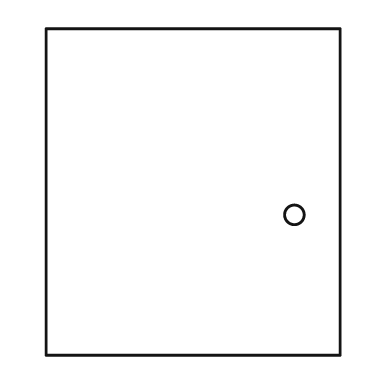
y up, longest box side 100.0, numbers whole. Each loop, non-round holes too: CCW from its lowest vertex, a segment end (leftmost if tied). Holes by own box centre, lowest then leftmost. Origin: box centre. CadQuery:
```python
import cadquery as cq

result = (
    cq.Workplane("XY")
    .moveTo(-45.0, -50.0)
    .lineTo(45.0, -50.0)
    .lineTo(45.0, 50.0)
    .lineTo(-45.0, 50.0)
    .close()
    .moveTo(31.0, -7.0)
    .circle(3.0)
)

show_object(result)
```